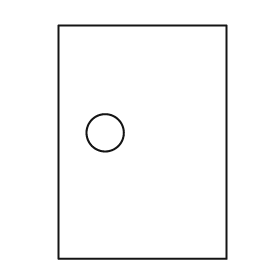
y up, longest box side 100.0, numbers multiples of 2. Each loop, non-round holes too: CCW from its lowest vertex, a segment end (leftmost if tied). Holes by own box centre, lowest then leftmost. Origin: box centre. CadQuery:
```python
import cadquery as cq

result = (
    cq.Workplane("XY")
    .moveTo(-36.0, -50.0)
    .lineTo(36.0, -50.0)
    .lineTo(36.0, 50.0)
    .lineTo(-36.0, 50.0)
    .close()
    .moveTo(-16.0, 4.0)
    .circle(8.0)
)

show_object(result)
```